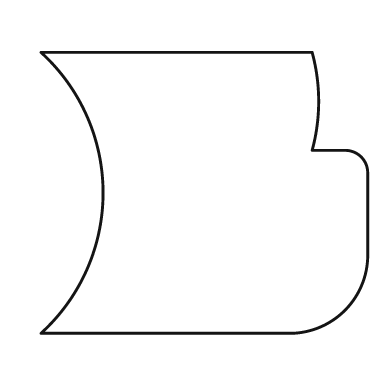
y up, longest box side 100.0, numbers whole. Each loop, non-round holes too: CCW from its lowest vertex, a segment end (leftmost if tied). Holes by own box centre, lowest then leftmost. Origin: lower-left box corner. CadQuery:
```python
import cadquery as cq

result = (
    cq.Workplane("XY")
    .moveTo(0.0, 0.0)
    .lineTo(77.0, 0.0)
    .threePointArc((93.0, 7.0), (100.0, 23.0))
    .lineTo(100.0, 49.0)
    .threePointArc((98.0, 54.0), (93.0, 56.0))
    .lineTo(83.0, 56.0)
    .threePointArc((85.0, 71.0), (83.0, 86.0))
    .lineTo(0.0, 86.0)
    .threePointArc((19.0, 43.0), (0.0, 0.0))
    .close()
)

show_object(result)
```